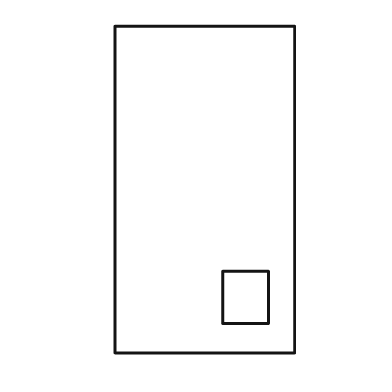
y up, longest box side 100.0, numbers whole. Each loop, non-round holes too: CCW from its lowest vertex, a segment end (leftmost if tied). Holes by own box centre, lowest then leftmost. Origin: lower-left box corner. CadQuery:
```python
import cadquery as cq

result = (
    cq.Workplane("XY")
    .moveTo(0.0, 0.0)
    .lineTo(55.0, 0.0)
    .lineTo(55.0, 100.0)
    .lineTo(0.0, 100.0)
    .close()
    .moveTo(33.0, 9.0)
    .lineTo(47.0, 9.0)
    .lineTo(47.0, 25.0)
    .lineTo(33.0, 25.0)
    .close()
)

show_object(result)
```